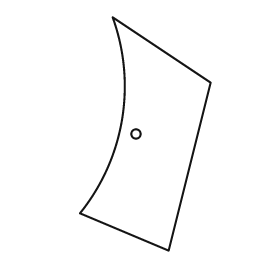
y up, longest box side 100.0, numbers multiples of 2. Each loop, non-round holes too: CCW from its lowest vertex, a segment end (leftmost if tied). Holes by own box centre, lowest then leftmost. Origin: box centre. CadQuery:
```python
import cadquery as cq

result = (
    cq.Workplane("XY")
    .moveTo(10.0, -50.0)
    .lineTo(28.0, 22.0)
    .lineTo(-14.0, 50.0)
    .threePointArc((-10.0, 6.0), (-28.0, -34.0))
    .close()
    .moveTo(-4.0, 0.0)
    .circle(2.0)
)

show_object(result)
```